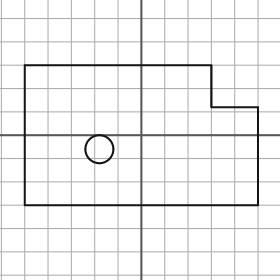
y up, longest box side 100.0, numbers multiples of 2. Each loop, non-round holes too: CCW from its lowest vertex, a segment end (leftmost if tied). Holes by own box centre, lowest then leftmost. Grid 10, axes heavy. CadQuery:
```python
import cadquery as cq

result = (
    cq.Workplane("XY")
    .moveTo(-50.0, -30.0)
    .lineTo(50.0, -30.0)
    .lineTo(50.0, 12.0)
    .lineTo(30.0, 12.0)
    .lineTo(30.0, 30.0)
    .lineTo(-50.0, 30.0)
    .close()
    .moveTo(-18.0, -6.0)
    .circle(6.0)
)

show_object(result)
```